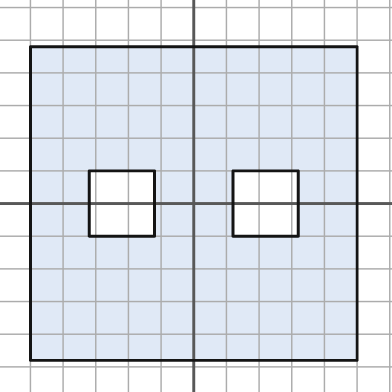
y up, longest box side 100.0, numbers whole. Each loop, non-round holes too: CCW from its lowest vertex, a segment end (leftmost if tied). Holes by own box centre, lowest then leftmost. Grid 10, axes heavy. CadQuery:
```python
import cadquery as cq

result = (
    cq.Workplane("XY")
    .moveTo(-50.0, -48.0)
    .lineTo(50.0, -48.0)
    .lineTo(50.0, 48.0)
    .lineTo(-50.0, 48.0)
    .close()
    .moveTo(-32.0, -10.0)
    .lineTo(-12.0, -10.0)
    .lineTo(-12.0, 10.0)
    .lineTo(-32.0, 10.0)
    .close()
    .moveTo(12.0, -10.0)
    .lineTo(32.0, -10.0)
    .lineTo(32.0, 10.0)
    .lineTo(12.0, 10.0)
    .close()
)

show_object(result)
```